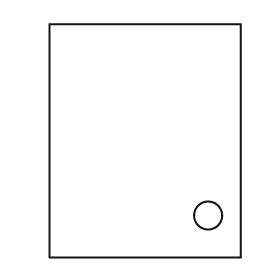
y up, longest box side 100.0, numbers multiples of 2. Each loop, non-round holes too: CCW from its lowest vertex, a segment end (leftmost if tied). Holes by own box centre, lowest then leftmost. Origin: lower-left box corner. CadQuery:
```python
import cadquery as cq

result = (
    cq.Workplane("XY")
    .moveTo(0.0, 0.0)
    .lineTo(82.0, 0.0)
    .lineTo(82.0, 100.0)
    .lineTo(0.0, 100.0)
    .close()
    .moveTo(68.0, 18.0)
    .circle(6.0)
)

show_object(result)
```